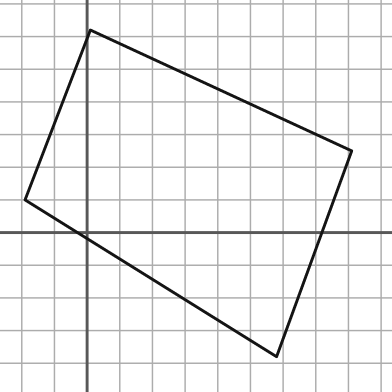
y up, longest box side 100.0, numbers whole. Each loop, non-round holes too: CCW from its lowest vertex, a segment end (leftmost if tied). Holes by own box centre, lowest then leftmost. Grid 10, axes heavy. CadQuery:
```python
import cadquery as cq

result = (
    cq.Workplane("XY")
    .moveTo(58.0, -38.0)
    .lineTo(81.0, 25.0)
    .lineTo(1.0, 62.0)
    .lineTo(-19.0, 10.0)
    .close()
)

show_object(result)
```